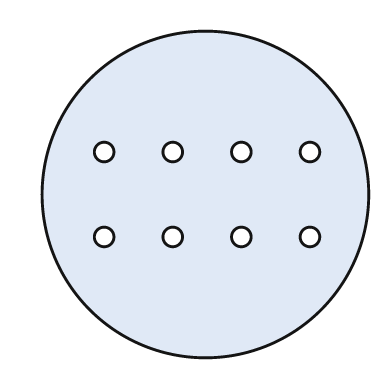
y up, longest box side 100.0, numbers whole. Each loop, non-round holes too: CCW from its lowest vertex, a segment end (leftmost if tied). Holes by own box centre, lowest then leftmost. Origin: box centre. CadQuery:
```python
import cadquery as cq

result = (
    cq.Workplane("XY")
    .moveTo(0.0, 0.0)
    .circle(50.0)
    .moveTo(-31.0, -13.0)
    .circle(3.0)
    .moveTo(-10.0, -13.0)
    .circle(3.0)
    .moveTo(11.0, -13.0)
    .circle(3.0)
    .moveTo(32.0, -13.0)
    .circle(3.0)
    .moveTo(-31.0, 13.0)
    .circle(3.0)
    .moveTo(-10.0, 13.0)
    .circle(3.0)
    .moveTo(11.0, 13.0)
    .circle(3.0)
    .moveTo(32.0, 13.0)
    .circle(3.0)
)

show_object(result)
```